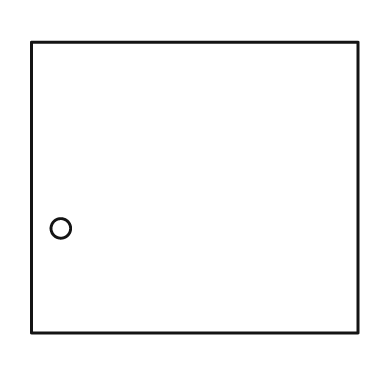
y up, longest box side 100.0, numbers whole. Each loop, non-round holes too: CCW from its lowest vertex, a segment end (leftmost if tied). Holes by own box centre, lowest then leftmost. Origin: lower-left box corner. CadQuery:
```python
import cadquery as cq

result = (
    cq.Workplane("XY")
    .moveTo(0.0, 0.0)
    .lineTo(100.0, 0.0)
    .lineTo(100.0, 89.0)
    .lineTo(0.0, 89.0)
    .close()
    .moveTo(9.0, 32.0)
    .circle(3.0)
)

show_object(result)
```